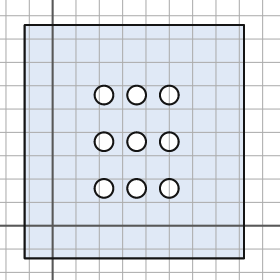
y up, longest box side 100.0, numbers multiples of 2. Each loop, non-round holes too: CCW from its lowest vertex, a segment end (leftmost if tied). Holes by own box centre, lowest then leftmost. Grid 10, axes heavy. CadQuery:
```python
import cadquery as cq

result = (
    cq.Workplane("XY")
    .moveTo(-12.0, -14.0)
    .lineTo(82.0, -14.0)
    .lineTo(82.0, 86.0)
    .lineTo(-12.0, 86.0)
    .close()
    .moveTo(22.0, 16.0)
    .circle(4.0)
    .moveTo(36.0, 16.0)
    .circle(4.0)
    .moveTo(50.0, 16.0)
    .circle(4.0)
    .moveTo(22.0, 36.0)
    .circle(4.0)
    .moveTo(36.0, 36.0)
    .circle(4.0)
    .moveTo(50.0, 36.0)
    .circle(4.0)
    .moveTo(22.0, 56.0)
    .circle(4.0)
    .moveTo(36.0, 56.0)
    .circle(4.0)
    .moveTo(50.0, 56.0)
    .circle(4.0)
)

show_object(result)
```